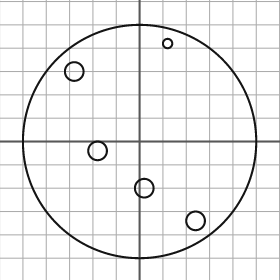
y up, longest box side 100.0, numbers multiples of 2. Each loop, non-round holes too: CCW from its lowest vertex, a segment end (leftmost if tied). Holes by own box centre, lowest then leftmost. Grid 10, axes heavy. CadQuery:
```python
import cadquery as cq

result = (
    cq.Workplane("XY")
    .moveTo(0.0, 0.0)
    .circle(50.0)
    .moveTo(24.0, -34.0)
    .circle(4.0)
    .moveTo(2.0, -20.0)
    .circle(4.0)
    .moveTo(-18.0, -4.0)
    .circle(4.0)
    .moveTo(-28.0, 30.0)
    .circle(4.0)
    .moveTo(12.0, 42.0)
    .circle(2.0)
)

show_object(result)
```